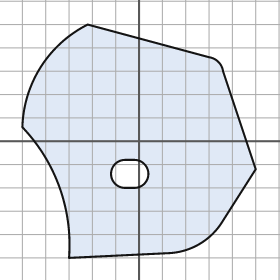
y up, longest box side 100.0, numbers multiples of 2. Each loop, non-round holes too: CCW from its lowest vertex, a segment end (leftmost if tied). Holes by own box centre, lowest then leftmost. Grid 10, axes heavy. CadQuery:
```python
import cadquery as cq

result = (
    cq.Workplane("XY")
    .moveTo(-30.0, -50.0)
    .lineTo(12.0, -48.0)
    .threePointArc((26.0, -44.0), (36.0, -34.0))
    .lineTo(50.0, -12.0)
    .lineTo(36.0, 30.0)
    .threePointArc((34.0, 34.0), (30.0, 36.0))
    .lineTo(-22.0, 50.0)
    .threePointArc((-42.0, 32.0), (-50.0, 6.0))
    .threePointArc((-34.0, -20.0), (-30.0, -50.0))
    .close()
    .moveTo(-6.0, -20.0)
    .lineTo(-2.0, -20.0)
    .threePointArc((4.0, -14.0), (-2.0, -8.0))
    .lineTo(-6.0, -8.0)
    .threePointArc((-12.0, -14.0), (-6.0, -20.0))
    .close()
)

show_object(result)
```